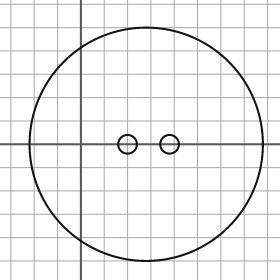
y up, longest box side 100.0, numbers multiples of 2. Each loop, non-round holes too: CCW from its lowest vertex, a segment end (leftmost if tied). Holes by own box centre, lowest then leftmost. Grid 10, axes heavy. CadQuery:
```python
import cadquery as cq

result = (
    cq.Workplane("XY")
    .moveTo(28.0, 0.0)
    .circle(50.0)
    .moveTo(20.0, 0.0)
    .circle(4.0)
    .moveTo(38.0, 0.0)
    .circle(4.0)
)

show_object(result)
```